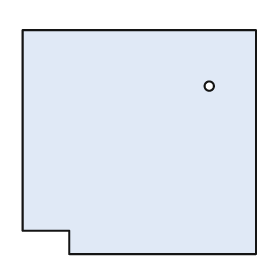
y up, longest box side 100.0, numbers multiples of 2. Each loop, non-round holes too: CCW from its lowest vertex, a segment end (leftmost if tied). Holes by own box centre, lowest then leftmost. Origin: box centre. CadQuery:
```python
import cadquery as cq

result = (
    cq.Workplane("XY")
    .moveTo(-30.0, -48.0)
    .lineTo(50.0, -48.0)
    .lineTo(50.0, 48.0)
    .lineTo(-50.0, 48.0)
    .lineTo(-50.0, -38.0)
    .lineTo(-30.0, -38.0)
    .close()
    .moveTo(30.0, 24.0)
    .circle(2.0)
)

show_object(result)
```